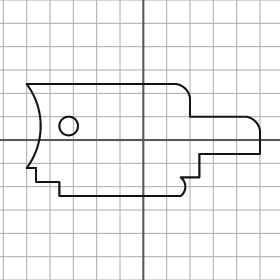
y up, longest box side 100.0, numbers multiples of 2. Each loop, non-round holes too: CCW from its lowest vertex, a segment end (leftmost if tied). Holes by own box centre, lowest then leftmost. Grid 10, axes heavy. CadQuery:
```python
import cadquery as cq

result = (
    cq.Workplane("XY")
    .moveTo(-36.0, -24.0)
    .lineTo(16.0, -24.0)
    .threePointArc((18.0, -20.0), (16.0, -16.0))
    .lineTo(24.0, -16.0)
    .lineTo(24.0, -6.0)
    .lineTo(50.0, -6.0)
    .lineTo(50.0, 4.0)
    .threePointArc((48.0, 8.0), (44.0, 10.0))
    .lineTo(20.0, 10.0)
    .lineTo(20.0, 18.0)
    .threePointArc((18.0, 22.0), (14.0, 24.0))
    .lineTo(-50.0, 24.0)
    .threePointArc((-44.0, 6.0), (-50.0, -12.0))
    .lineTo(-46.0, -12.0)
    .lineTo(-46.0, -18.0)
    .lineTo(-36.0, -18.0)
    .close()
    .moveTo(-32.0, 6.0)
    .circle(4.0)
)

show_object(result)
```